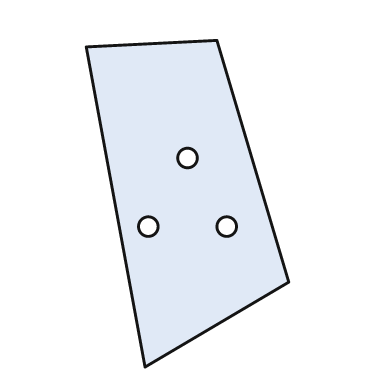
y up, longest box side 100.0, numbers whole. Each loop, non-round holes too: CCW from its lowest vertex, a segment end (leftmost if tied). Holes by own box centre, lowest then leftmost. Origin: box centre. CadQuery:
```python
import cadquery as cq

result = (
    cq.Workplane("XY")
    .moveTo(-13.0, -50.0)
    .lineTo(31.0, -24.0)
    .lineTo(9.0, 50.0)
    .lineTo(-31.0, 48.0)
    .close()
    .moveTo(-12.0, -7.0)
    .circle(3.0)
    .moveTo(12.0, -7.0)
    .circle(3.0)
    .moveTo(0.0, 14.0)
    .circle(3.0)
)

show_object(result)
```